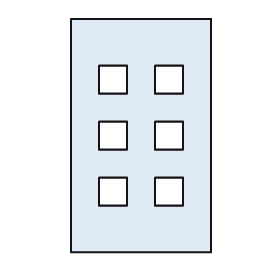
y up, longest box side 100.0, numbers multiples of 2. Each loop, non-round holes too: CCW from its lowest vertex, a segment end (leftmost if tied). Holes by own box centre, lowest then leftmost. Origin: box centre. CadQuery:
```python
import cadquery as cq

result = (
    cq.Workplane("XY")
    .moveTo(-30.0, -50.0)
    .lineTo(30.0, -50.0)
    .lineTo(30.0, 50.0)
    .lineTo(-30.0, 50.0)
    .close()
    .moveTo(-18.0, -30.0)
    .lineTo(-6.0, -30.0)
    .lineTo(-6.0, -18.0)
    .lineTo(-18.0, -18.0)
    .close()
    .moveTo(6.0, -30.0)
    .lineTo(18.0, -30.0)
    .lineTo(18.0, -18.0)
    .lineTo(6.0, -18.0)
    .close()
    .moveTo(-18.0, -6.0)
    .lineTo(-6.0, -6.0)
    .lineTo(-6.0, 6.0)
    .lineTo(-18.0, 6.0)
    .close()
    .moveTo(6.0, -6.0)
    .lineTo(18.0, -6.0)
    .lineTo(18.0, 6.0)
    .lineTo(6.0, 6.0)
    .close()
    .moveTo(-18.0, 18.0)
    .lineTo(-6.0, 18.0)
    .lineTo(-6.0, 30.0)
    .lineTo(-18.0, 30.0)
    .close()
    .moveTo(6.0, 18.0)
    .lineTo(18.0, 18.0)
    .lineTo(18.0, 30.0)
    .lineTo(6.0, 30.0)
    .close()
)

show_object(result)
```